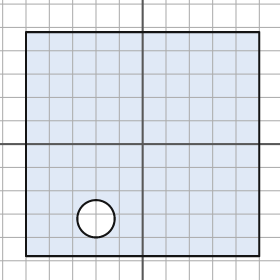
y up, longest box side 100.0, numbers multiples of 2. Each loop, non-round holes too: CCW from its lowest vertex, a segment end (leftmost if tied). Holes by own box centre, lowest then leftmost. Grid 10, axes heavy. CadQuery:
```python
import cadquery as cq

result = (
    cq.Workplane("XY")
    .moveTo(-50.0, -48.0)
    .lineTo(50.0, -48.0)
    .lineTo(50.0, 48.0)
    .lineTo(-50.0, 48.0)
    .close()
    .moveTo(-20.0, -32.0)
    .circle(8.0)
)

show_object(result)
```